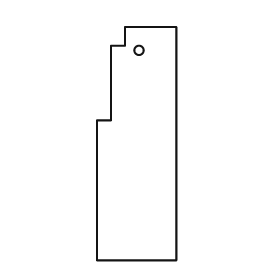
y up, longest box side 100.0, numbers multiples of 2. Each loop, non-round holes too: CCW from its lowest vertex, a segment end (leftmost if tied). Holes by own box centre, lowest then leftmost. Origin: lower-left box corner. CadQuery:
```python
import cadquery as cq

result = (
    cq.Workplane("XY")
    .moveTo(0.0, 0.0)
    .lineTo(34.0, 0.0)
    .lineTo(34.0, 100.0)
    .lineTo(12.0, 100.0)
    .lineTo(12.0, 92.0)
    .lineTo(6.0, 92.0)
    .lineTo(6.0, 60.0)
    .lineTo(0.0, 60.0)
    .close()
    .moveTo(18.0, 90.0)
    .circle(2.0)
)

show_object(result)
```